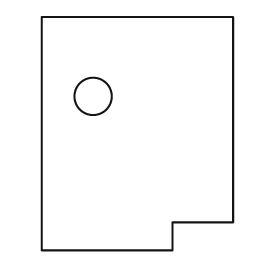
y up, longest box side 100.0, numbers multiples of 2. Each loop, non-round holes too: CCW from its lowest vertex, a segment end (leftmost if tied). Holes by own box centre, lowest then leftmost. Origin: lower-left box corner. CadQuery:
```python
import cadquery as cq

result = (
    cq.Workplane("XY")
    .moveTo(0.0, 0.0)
    .lineTo(56.0, 0.0)
    .lineTo(56.0, 12.0)
    .lineTo(82.0, 12.0)
    .lineTo(82.0, 100.0)
    .lineTo(0.0, 100.0)
    .close()
    .moveTo(22.0, 66.0)
    .circle(8.0)
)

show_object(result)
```